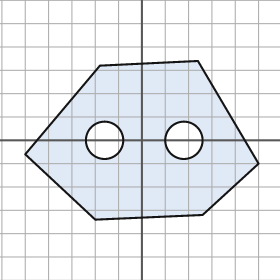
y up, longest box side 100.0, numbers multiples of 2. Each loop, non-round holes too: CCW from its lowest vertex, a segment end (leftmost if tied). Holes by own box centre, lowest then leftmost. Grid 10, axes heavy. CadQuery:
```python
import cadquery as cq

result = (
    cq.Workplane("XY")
    .moveTo(-20.0, -34.0)
    .lineTo(26.0, -32.0)
    .lineTo(50.0, -10.0)
    .lineTo(24.0, 34.0)
    .lineTo(-18.0, 32.0)
    .lineTo(-50.0, -6.0)
    .close()
    .moveTo(-16.0, 0.0)
    .circle(8.0)
    .moveTo(18.0, 0.0)
    .circle(8.0)
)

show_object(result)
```